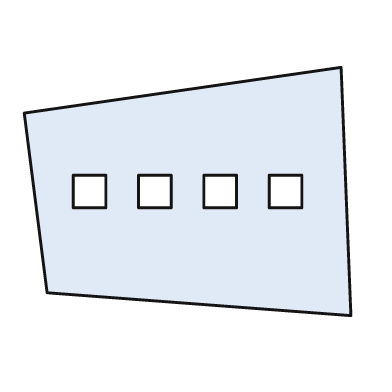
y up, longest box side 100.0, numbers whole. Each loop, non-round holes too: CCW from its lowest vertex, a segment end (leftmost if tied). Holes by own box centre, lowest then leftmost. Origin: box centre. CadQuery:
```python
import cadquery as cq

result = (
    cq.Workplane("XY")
    .moveTo(50.0, -38.0)
    .lineTo(47.0, 38.0)
    .lineTo(-50.0, 24.0)
    .lineTo(-43.0, -31.0)
    .close()
    .moveTo(-35.0, -5.0)
    .lineTo(-25.0, -5.0)
    .lineTo(-25.0, 5.0)
    .lineTo(-35.0, 5.0)
    .close()
    .moveTo(-15.0, -5.0)
    .lineTo(-5.0, -5.0)
    .lineTo(-5.0, 5.0)
    .lineTo(-15.0, 5.0)
    .close()
    .moveTo(5.0, -5.0)
    .lineTo(15.0, -5.0)
    .lineTo(15.0, 5.0)
    .lineTo(5.0, 5.0)
    .close()
    .moveTo(25.0, -5.0)
    .lineTo(35.0, -5.0)
    .lineTo(35.0, 5.0)
    .lineTo(25.0, 5.0)
    .close()
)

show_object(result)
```